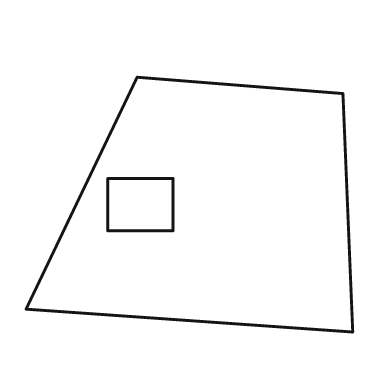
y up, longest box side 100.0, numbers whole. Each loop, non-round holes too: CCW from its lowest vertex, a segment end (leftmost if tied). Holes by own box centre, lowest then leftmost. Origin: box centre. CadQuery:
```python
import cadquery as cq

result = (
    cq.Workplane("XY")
    .moveTo(50.0, -39.0)
    .lineTo(47.0, 34.0)
    .lineTo(-16.0, 39.0)
    .lineTo(-50.0, -32.0)
    .close()
    .moveTo(-25.0, -8.0)
    .lineTo(-5.0, -8.0)
    .lineTo(-5.0, 8.0)
    .lineTo(-25.0, 8.0)
    .close()
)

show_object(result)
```